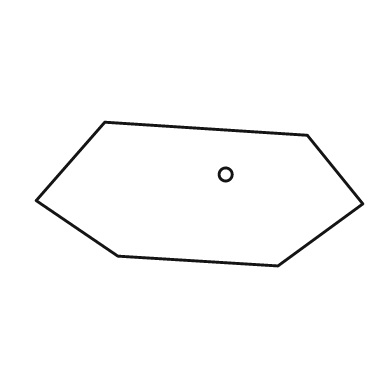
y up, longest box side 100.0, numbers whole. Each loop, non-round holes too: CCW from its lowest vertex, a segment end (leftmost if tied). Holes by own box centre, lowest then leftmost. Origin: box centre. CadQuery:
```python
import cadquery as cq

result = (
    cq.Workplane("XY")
    .moveTo(24.0, -22.0)
    .lineTo(50.0, -3.0)
    .lineTo(33.0, 18.0)
    .lineTo(-29.0, 22.0)
    .lineTo(-50.0, -2.0)
    .lineTo(-25.0, -19.0)
    .close()
    .moveTo(8.0, 6.0)
    .circle(2.0)
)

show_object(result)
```